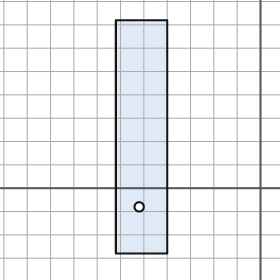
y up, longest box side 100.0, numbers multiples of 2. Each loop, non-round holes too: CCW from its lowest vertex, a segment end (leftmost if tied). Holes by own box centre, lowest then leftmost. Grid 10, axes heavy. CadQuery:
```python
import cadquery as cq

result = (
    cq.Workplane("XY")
    .moveTo(-62.0, -28.0)
    .lineTo(-40.0, -28.0)
    .lineTo(-40.0, 72.0)
    .lineTo(-62.0, 72.0)
    .close()
    .moveTo(-52.0, -8.0)
    .circle(2.0)
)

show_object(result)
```